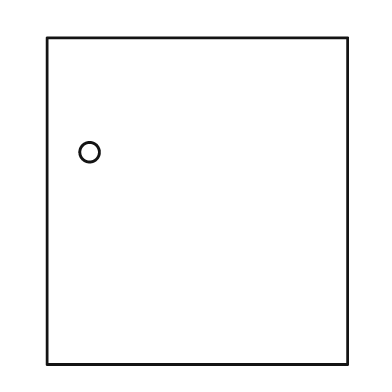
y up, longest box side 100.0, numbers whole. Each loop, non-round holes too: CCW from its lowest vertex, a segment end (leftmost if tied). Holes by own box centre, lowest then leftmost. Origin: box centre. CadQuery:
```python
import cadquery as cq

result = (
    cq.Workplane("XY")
    .moveTo(-46.0, -50.0)
    .lineTo(46.0, -50.0)
    .lineTo(46.0, 50.0)
    .lineTo(-46.0, 50.0)
    .close()
    .moveTo(-33.0, 15.0)
    .circle(3.0)
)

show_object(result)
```